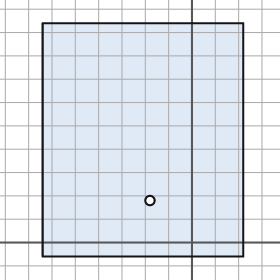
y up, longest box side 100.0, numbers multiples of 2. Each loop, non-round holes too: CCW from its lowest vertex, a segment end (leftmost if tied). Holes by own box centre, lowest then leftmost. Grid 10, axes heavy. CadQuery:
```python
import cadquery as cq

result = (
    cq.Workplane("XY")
    .moveTo(-64.0, -6.0)
    .lineTo(22.0, -6.0)
    .lineTo(22.0, 94.0)
    .lineTo(-64.0, 94.0)
    .close()
    .moveTo(-18.0, 18.0)
    .circle(2.0)
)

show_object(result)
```